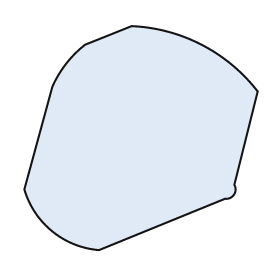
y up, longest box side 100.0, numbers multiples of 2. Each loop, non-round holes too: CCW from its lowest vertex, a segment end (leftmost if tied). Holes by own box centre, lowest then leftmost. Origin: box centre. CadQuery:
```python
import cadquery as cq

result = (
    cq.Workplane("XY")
    .moveTo(-18.0, -48.0)
    .lineTo(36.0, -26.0)
    .threePointArc((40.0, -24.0), (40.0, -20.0))
    .lineTo(50.0, 20.0)
    .threePointArc((26.0, 40.0), (-4.0, 48.0))
    .lineTo(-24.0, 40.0)
    .threePointArc((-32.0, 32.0), (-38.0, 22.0))
    .lineTo(-50.0, -22.0)
    .threePointArc((-38.0, -40.0), (-18.0, -48.0))
    .close()
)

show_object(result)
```